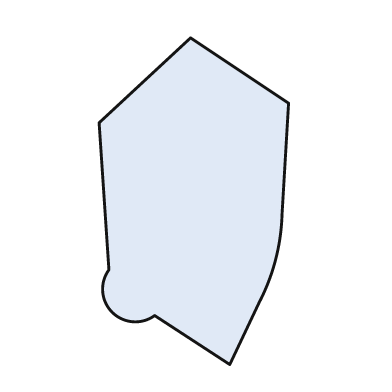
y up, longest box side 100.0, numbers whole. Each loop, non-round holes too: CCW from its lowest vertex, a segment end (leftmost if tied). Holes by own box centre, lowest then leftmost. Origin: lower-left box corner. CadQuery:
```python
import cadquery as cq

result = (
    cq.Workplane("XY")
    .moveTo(40.0, 0.0)
    .lineTo(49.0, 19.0)
    .threePointArc((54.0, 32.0), (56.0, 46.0))
    .lineTo(58.0, 80.0)
    .lineTo(28.0, 100.0)
    .lineTo(0.0, 74.0)
    .lineTo(3.0, 29.0)
    .threePointArc((4.0, 16.0), (17.0, 15.0))
    .close()
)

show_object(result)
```